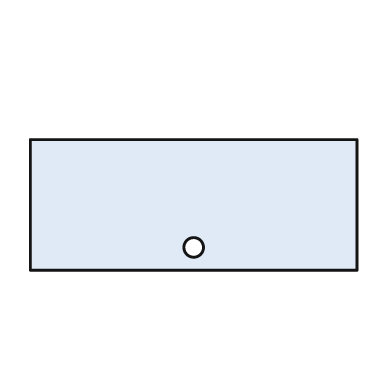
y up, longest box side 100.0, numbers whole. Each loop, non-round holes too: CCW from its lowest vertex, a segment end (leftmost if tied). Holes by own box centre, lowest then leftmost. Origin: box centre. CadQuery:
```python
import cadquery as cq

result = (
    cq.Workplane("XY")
    .moveTo(-50.0, -20.0)
    .lineTo(50.0, -20.0)
    .lineTo(50.0, 20.0)
    .lineTo(-50.0, 20.0)
    .close()
    .moveTo(0.0, -13.0)
    .circle(3.0)
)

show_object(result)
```